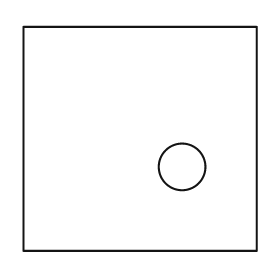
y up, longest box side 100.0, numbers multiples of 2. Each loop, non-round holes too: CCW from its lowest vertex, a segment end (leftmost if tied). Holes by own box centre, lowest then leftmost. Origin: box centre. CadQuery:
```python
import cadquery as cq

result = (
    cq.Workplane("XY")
    .moveTo(-50.0, -48.0)
    .lineTo(50.0, -48.0)
    .lineTo(50.0, 48.0)
    .lineTo(-50.0, 48.0)
    .close()
    .moveTo(18.0, -12.0)
    .circle(10.0)
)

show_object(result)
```